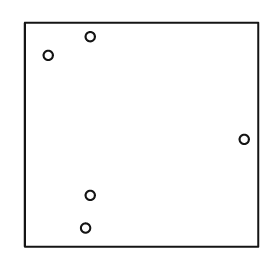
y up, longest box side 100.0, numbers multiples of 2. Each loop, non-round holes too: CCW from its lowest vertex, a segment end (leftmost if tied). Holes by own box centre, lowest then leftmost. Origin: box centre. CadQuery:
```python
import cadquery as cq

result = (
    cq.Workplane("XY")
    .moveTo(-50.0, -48.0)
    .lineTo(50.0, -48.0)
    .lineTo(50.0, 48.0)
    .lineTo(-50.0, 48.0)
    .close()
    .moveTo(-24.0, -40.0)
    .circle(2.0)
    .moveTo(-22.0, -26.0)
    .circle(2.0)
    .moveTo(44.0, -2.0)
    .circle(2.0)
    .moveTo(-40.0, 34.0)
    .circle(2.0)
    .moveTo(-22.0, 42.0)
    .circle(2.0)
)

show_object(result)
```